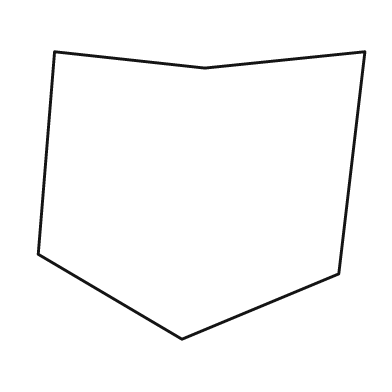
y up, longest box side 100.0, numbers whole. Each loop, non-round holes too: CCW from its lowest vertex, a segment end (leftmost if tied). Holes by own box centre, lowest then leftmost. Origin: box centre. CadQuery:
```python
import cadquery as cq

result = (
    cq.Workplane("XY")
    .moveTo(-6.0, -44.0)
    .lineTo(42.0, -24.0)
    .lineTo(50.0, 44.0)
    .lineTo(1.0, 39.0)
    .lineTo(-45.0, 44.0)
    .lineTo(-50.0, -18.0)
    .close()
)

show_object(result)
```